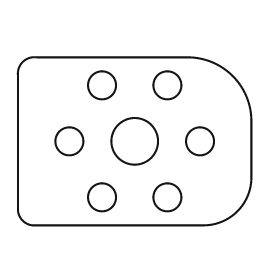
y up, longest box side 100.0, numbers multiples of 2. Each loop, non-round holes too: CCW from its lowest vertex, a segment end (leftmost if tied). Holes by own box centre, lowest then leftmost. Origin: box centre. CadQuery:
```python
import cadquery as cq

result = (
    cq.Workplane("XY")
    .moveTo(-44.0, -36.0)
    .lineTo(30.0, -36.0)
    .threePointArc((44.0, -30.0), (50.0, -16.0))
    .lineTo(50.0, 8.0)
    .threePointArc((42.0, 28.0), (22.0, 36.0))
    .lineTo(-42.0, 36.0)
    .threePointArc((-48.0, 34.0), (-50.0, 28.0))
    .lineTo(-50.0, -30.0)
    .threePointArc((-48.0, -34.0), (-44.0, -36.0))
    .close()
    .moveTo(-14.0, -24.0)
    .circle(6.0)
    .moveTo(14.0, -24.0)
    .circle(6.0)
    .moveTo(-28.0, 0.0)
    .circle(6.0)
    .moveTo(0.0, 0.0)
    .circle(10.0)
    .moveTo(28.0, 0.0)
    .circle(6.0)
    .moveTo(-14.0, 24.0)
    .circle(6.0)
    .moveTo(14.0, 24.0)
    .circle(6.0)
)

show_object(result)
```